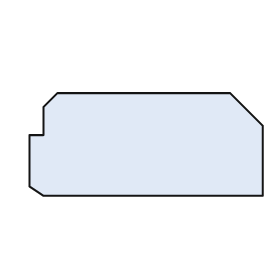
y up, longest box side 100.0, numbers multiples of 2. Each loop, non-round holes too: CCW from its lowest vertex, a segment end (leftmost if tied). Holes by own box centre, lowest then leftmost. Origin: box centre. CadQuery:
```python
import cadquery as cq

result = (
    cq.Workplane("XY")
    .moveTo(-44.0, -22.0)
    .lineTo(50.0, -22.0)
    .lineTo(50.0, 8.0)
    .lineTo(36.0, 22.0)
    .lineTo(-38.0, 22.0)
    .lineTo(-44.0, 16.0)
    .lineTo(-44.0, 4.0)
    .lineTo(-50.0, 4.0)
    .lineTo(-50.0, -18.0)
    .close()
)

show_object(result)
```